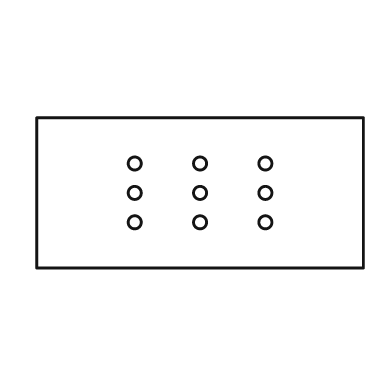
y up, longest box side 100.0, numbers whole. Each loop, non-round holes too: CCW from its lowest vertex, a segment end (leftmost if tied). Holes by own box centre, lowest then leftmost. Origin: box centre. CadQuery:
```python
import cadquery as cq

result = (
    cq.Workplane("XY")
    .moveTo(-50.0, -23.0)
    .lineTo(50.0, -23.0)
    .lineTo(50.0, 23.0)
    .lineTo(-50.0, 23.0)
    .close()
    .moveTo(-20.0, -9.0)
    .circle(2.0)
    .moveTo(0.0, -9.0)
    .circle(2.0)
    .moveTo(20.0, -9.0)
    .circle(2.0)
    .moveTo(-20.0, 0.0)
    .circle(2.0)
    .moveTo(0.0, 0.0)
    .circle(2.0)
    .moveTo(20.0, 0.0)
    .circle(2.0)
    .moveTo(-20.0, 9.0)
    .circle(2.0)
    .moveTo(0.0, 9.0)
    .circle(2.0)
    .moveTo(20.0, 9.0)
    .circle(2.0)
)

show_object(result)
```